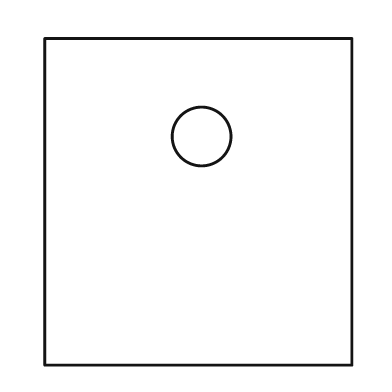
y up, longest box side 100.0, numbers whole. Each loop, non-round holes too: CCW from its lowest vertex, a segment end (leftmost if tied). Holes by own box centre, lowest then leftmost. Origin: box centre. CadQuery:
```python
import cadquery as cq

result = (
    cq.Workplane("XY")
    .moveTo(-47.0, -50.0)
    .lineTo(47.0, -50.0)
    .lineTo(47.0, 50.0)
    .lineTo(-47.0, 50.0)
    .close()
    .moveTo(1.0, 20.0)
    .circle(9.0)
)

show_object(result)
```